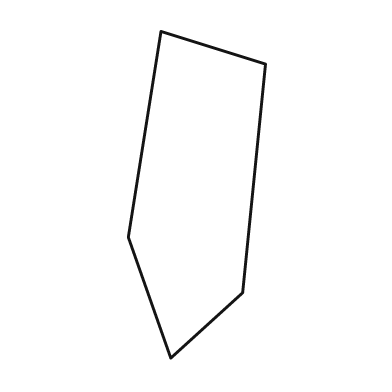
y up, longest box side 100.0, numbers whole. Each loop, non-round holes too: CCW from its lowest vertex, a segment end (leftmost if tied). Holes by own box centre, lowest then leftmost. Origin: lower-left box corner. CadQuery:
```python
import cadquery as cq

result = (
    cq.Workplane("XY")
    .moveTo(13.0, 0.0)
    .lineTo(35.0, 20.0)
    .lineTo(42.0, 90.0)
    .lineTo(10.0, 100.0)
    .lineTo(0.0, 37.0)
    .close()
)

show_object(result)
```